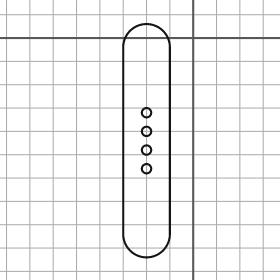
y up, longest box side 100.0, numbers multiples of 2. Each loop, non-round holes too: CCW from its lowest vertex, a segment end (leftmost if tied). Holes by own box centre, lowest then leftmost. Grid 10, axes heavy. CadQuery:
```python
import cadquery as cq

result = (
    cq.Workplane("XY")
    .moveTo(-30.0, -84.0)
    .threePointArc((-20.0, -94.0), (-10.0, -84.0))
    .lineTo(-10.0, -4.0)
    .threePointArc((-20.0, 6.0), (-30.0, -4.0))
    .close()
    .moveTo(-20.0, -56.0)
    .circle(2.0)
    .moveTo(-20.0, -48.0)
    .circle(2.0)
    .moveTo(-20.0, -40.0)
    .circle(2.0)
    .moveTo(-20.0, -32.0)
    .circle(2.0)
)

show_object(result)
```